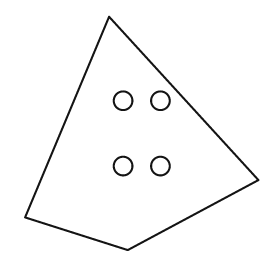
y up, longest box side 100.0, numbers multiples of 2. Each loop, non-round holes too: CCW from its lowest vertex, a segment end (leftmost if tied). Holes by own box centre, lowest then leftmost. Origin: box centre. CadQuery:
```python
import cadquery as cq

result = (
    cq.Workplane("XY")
    .moveTo(-6.0, -50.0)
    .lineTo(50.0, -20.0)
    .lineTo(-14.0, 50.0)
    .lineTo(-50.0, -36.0)
    .close()
    .moveTo(-8.0, -14.0)
    .circle(4.0)
    .moveTo(8.0, -14.0)
    .circle(4.0)
    .moveTo(-8.0, 14.0)
    .circle(4.0)
    .moveTo(8.0, 14.0)
    .circle(4.0)
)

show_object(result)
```